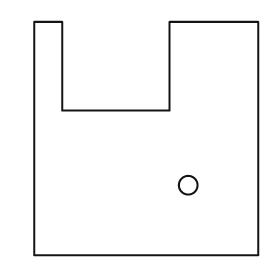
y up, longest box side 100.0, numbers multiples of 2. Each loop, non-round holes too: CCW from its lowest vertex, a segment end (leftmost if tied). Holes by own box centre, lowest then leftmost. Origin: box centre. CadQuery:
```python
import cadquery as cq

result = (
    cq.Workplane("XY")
    .moveTo(-48.0, -50.0)
    .lineTo(48.0, -50.0)
    .lineTo(48.0, 50.0)
    .lineTo(10.0, 50.0)
    .lineTo(10.0, 12.0)
    .lineTo(-36.0, 12.0)
    .lineTo(-36.0, 50.0)
    .lineTo(-48.0, 50.0)
    .close()
    .moveTo(18.0, -20.0)
    .circle(4.0)
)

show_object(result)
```